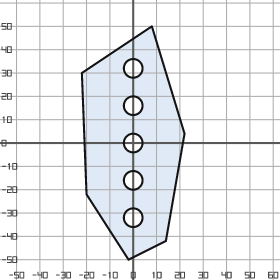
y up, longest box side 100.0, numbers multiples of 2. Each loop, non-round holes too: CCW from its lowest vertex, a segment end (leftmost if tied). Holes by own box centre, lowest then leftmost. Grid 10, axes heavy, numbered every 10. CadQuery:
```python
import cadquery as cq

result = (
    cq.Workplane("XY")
    .moveTo(-2.0, -50.0)
    .lineTo(14.0, -42.0)
    .lineTo(22.0, 4.0)
    .lineTo(8.0, 50.0)
    .lineTo(-22.0, 30.0)
    .lineTo(-20.0, -22.0)
    .close()
    .moveTo(0.0, -32.0)
    .circle(4.0)
    .moveTo(0.0, -16.0)
    .circle(4.0)
    .moveTo(0.0, 0.0)
    .circle(4.0)
    .moveTo(0.0, 16.0)
    .circle(4.0)
    .moveTo(0.0, 32.0)
    .circle(4.0)
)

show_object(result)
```